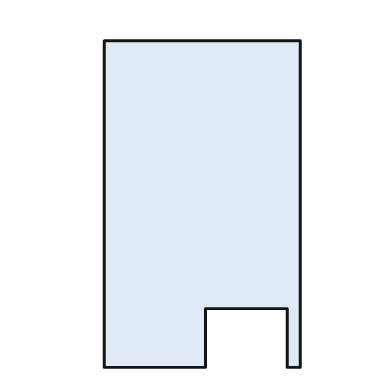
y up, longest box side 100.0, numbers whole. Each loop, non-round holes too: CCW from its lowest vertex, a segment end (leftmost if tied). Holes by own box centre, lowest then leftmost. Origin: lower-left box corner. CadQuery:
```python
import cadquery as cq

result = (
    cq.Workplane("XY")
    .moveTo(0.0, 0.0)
    .lineTo(31.0, 0.0)
    .lineTo(31.0, 18.0)
    .lineTo(56.0, 18.0)
    .lineTo(56.0, 0.0)
    .lineTo(60.0, 0.0)
    .lineTo(60.0, 100.0)
    .lineTo(0.0, 100.0)
    .close()
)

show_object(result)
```